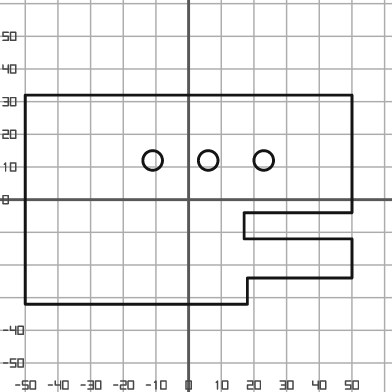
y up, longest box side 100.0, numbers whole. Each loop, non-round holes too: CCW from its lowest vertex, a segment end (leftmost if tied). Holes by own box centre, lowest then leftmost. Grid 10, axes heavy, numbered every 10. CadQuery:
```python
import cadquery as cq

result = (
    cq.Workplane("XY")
    .moveTo(-50.0, -32.0)
    .lineTo(18.0, -32.0)
    .lineTo(18.0, -24.0)
    .lineTo(50.0, -24.0)
    .lineTo(50.0, -12.0)
    .lineTo(17.0, -12.0)
    .lineTo(17.0, -4.0)
    .lineTo(50.0, -4.0)
    .lineTo(50.0, 32.0)
    .lineTo(-50.0, 32.0)
    .close()
    .moveTo(-11.0, 12.0)
    .circle(3.0)
    .moveTo(6.0, 12.0)
    .circle(3.0)
    .moveTo(23.0, 12.0)
    .circle(3.0)
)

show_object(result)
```